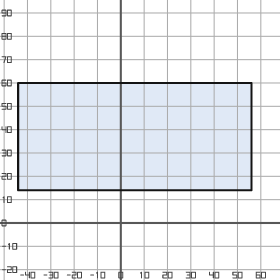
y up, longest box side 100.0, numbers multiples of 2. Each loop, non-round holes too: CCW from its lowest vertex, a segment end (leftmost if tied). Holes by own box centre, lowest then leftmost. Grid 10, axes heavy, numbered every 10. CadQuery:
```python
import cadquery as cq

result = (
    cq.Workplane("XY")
    .moveTo(-44.0, 14.0)
    .lineTo(56.0, 14.0)
    .lineTo(56.0, 60.0)
    .lineTo(-44.0, 60.0)
    .close()
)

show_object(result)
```